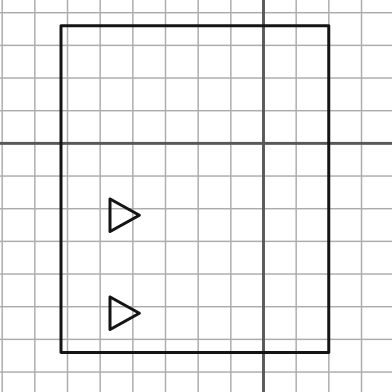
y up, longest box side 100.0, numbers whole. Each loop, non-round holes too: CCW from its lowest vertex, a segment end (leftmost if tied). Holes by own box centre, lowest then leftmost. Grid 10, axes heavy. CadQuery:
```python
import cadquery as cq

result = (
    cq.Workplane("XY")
    .moveTo(-62.0, -64.0)
    .lineTo(20.0, -64.0)
    .lineTo(20.0, 36.0)
    .lineTo(-62.0, 36.0)
    .close()
    .moveTo(-47.0, -57.0)
    .lineTo(-38.0, -52.0)
    .lineTo(-47.0, -47.0)
    .close()
    .moveTo(-47.0, -27.0)
    .lineTo(-38.0, -22.0)
    .lineTo(-47.0, -17.0)
    .close()
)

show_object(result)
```